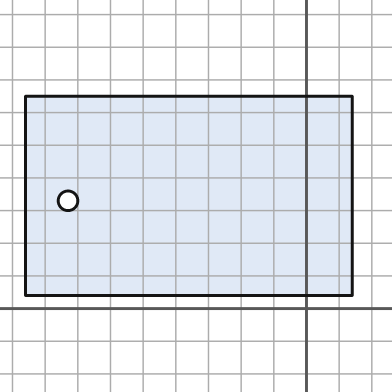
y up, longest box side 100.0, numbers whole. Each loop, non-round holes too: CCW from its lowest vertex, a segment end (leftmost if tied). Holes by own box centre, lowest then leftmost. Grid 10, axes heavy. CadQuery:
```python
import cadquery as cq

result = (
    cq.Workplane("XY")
    .moveTo(-86.0, 4.0)
    .lineTo(14.0, 4.0)
    .lineTo(14.0, 65.0)
    .lineTo(-86.0, 65.0)
    .close()
    .moveTo(-73.0, 33.0)
    .circle(3.0)
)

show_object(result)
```